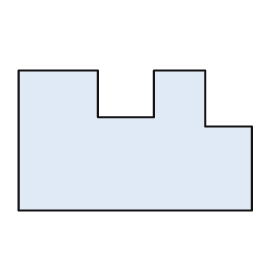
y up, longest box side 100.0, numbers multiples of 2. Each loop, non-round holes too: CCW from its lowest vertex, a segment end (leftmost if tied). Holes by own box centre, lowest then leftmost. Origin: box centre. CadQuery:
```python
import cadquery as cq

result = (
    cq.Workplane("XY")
    .moveTo(-50.0, -30.0)
    .lineTo(50.0, -30.0)
    .lineTo(50.0, 6.0)
    .lineTo(30.0, 6.0)
    .lineTo(30.0, 30.0)
    .lineTo(8.0, 30.0)
    .lineTo(8.0, 10.0)
    .lineTo(-16.0, 10.0)
    .lineTo(-16.0, 30.0)
    .lineTo(-50.0, 30.0)
    .close()
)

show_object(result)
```